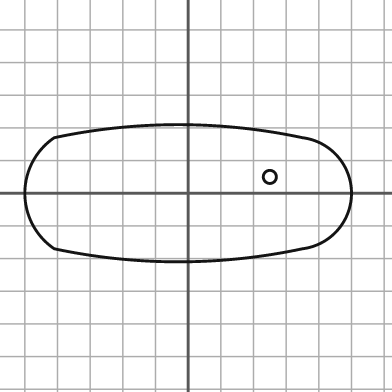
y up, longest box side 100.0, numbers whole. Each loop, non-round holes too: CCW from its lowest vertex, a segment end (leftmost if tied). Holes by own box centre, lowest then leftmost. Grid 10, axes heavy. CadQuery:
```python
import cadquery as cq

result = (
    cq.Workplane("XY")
    .moveTo(-41.0, -17.0)
    .threePointArc((-3.0, -21.0), (35.0, -17.0))
    .threePointArc((50.0, 0.0), (35.0, 17.0))
    .threePointArc((-3.0, 21.0), (-41.0, 17.0))
    .threePointArc((-50.0, 0.0), (-41.0, -17.0))
    .close()
    .moveTo(25.0, 5.0)
    .circle(2.0)
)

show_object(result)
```